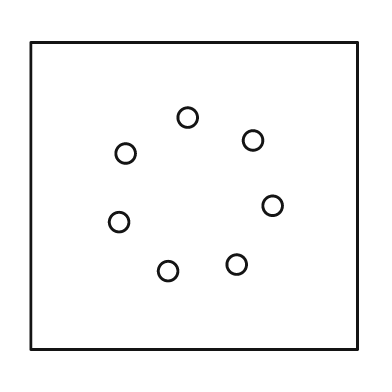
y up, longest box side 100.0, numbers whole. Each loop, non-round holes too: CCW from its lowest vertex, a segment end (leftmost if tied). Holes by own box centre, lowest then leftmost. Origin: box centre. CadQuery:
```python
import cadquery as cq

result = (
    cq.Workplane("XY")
    .moveTo(-50.0, -47.0)
    .lineTo(50.0, -47.0)
    .lineTo(50.0, 47.0)
    .lineTo(-50.0, 47.0)
    .close()
    .moveTo(-8.0, -23.0)
    .circle(3.0)
    .moveTo(13.0, -21.0)
    .circle(3.0)
    .moveTo(-23.0, -8.0)
    .circle(3.0)
    .moveTo(24.0, -3.0)
    .circle(3.0)
    .moveTo(-21.0, 13.0)
    .circle(3.0)
    .moveTo(18.0, 17.0)
    .circle(3.0)
    .moveTo(-2.0, 24.0)
    .circle(3.0)
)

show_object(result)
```